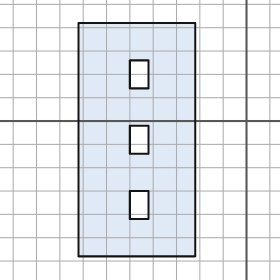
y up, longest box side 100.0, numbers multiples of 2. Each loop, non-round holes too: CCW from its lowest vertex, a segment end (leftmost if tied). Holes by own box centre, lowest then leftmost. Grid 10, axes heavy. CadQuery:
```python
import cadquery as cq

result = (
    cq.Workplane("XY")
    .moveTo(-72.0, -58.0)
    .lineTo(-22.0, -58.0)
    .lineTo(-22.0, 42.0)
    .lineTo(-72.0, 42.0)
    .close()
    .moveTo(-50.0, -42.0)
    .lineTo(-42.0, -42.0)
    .lineTo(-42.0, -30.0)
    .lineTo(-50.0, -30.0)
    .close()
    .moveTo(-50.0, -14.0)
    .lineTo(-42.0, -14.0)
    .lineTo(-42.0, -2.0)
    .lineTo(-50.0, -2.0)
    .close()
    .moveTo(-50.0, 14.0)
    .lineTo(-42.0, 14.0)
    .lineTo(-42.0, 26.0)
    .lineTo(-50.0, 26.0)
    .close()
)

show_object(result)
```